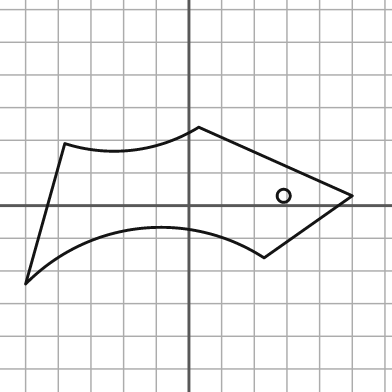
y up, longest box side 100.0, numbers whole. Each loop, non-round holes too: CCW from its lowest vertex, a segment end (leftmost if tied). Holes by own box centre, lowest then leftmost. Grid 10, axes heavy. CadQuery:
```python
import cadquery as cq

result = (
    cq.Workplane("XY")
    .moveTo(-50.0, -24.0)
    .threePointArc((-15.0, -7.0), (23.0, -16.0))
    .lineTo(50.0, 3.0)
    .lineTo(3.0, 24.0)
    .threePointArc((-17.0, 17.0), (-38.0, 19.0))
    .close()
    .moveTo(29.0, 3.0)
    .circle(2.0)
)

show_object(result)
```